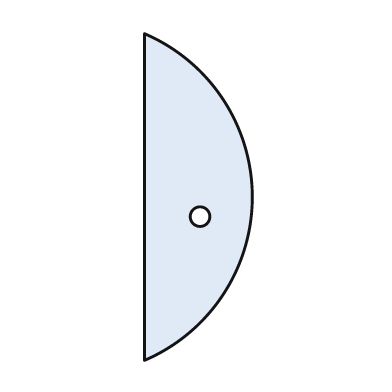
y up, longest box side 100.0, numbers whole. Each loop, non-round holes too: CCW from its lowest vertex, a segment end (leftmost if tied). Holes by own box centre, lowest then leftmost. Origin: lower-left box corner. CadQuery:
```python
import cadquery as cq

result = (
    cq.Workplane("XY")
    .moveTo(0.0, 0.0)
    .threePointArc((33.0, 50.0), (0.0, 100.0))
    .close()
    .moveTo(17.0, 44.0)
    .circle(3.0)
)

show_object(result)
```